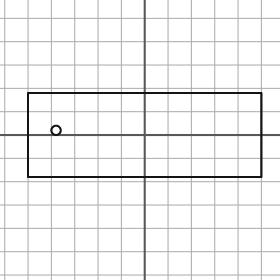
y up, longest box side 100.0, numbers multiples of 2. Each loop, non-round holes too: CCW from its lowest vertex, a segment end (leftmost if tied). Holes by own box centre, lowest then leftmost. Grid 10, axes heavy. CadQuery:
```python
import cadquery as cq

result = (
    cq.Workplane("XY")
    .moveTo(-50.0, -18.0)
    .lineTo(50.0, -18.0)
    .lineTo(50.0, 18.0)
    .lineTo(-50.0, 18.0)
    .close()
    .moveTo(-38.0, 2.0)
    .circle(2.0)
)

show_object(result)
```